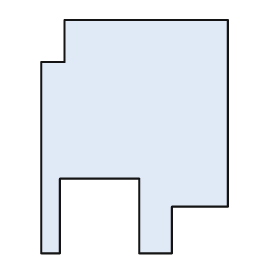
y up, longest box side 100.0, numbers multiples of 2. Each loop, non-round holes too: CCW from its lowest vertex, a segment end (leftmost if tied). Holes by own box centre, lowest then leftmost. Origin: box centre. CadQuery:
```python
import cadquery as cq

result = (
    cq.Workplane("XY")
    .moveTo(-40.0, -50.0)
    .lineTo(-32.0, -50.0)
    .lineTo(-32.0, -18.0)
    .lineTo(2.0, -18.0)
    .lineTo(2.0, -50.0)
    .lineTo(16.0, -50.0)
    .lineTo(16.0, -30.0)
    .lineTo(40.0, -30.0)
    .lineTo(40.0, 50.0)
    .lineTo(-30.0, 50.0)
    .lineTo(-30.0, 32.0)
    .lineTo(-40.0, 32.0)
    .close()
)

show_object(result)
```